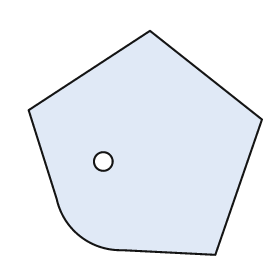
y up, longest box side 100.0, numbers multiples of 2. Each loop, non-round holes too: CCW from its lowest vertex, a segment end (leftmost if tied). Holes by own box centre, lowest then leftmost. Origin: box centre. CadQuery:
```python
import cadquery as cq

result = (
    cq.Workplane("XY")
    .moveTo(30.0, -48.0)
    .lineTo(50.0, 10.0)
    .lineTo(2.0, 48.0)
    .lineTo(-50.0, 14.0)
    .lineTo(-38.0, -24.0)
    .threePointArc((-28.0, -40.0), (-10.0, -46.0))
    .close()
    .moveTo(-18.0, -8.0)
    .circle(4.0)
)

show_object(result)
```